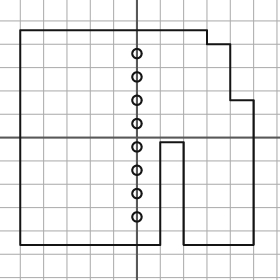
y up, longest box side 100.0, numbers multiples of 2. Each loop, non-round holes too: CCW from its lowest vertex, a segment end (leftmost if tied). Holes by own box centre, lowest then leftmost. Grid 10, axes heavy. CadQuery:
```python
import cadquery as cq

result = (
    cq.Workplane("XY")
    .moveTo(-50.0, -46.0)
    .lineTo(10.0, -46.0)
    .lineTo(10.0, -2.0)
    .lineTo(20.0, -2.0)
    .lineTo(20.0, -46.0)
    .lineTo(50.0, -46.0)
    .lineTo(50.0, 16.0)
    .lineTo(40.0, 16.0)
    .lineTo(40.0, 40.0)
    .lineTo(30.0, 40.0)
    .lineTo(30.0, 46.0)
    .lineTo(-50.0, 46.0)
    .close()
    .moveTo(0.0, -34.0)
    .circle(2.0)
    .moveTo(0.0, -24.0)
    .circle(2.0)
    .moveTo(0.0, -14.0)
    .circle(2.0)
    .moveTo(0.0, -4.0)
    .circle(2.0)
    .moveTo(0.0, 6.0)
    .circle(2.0)
    .moveTo(0.0, 16.0)
    .circle(2.0)
    .moveTo(0.0, 26.0)
    .circle(2.0)
    .moveTo(0.0, 36.0)
    .circle(2.0)
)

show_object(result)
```